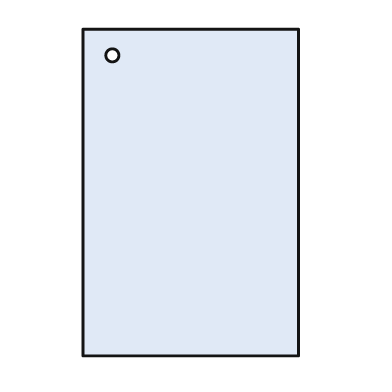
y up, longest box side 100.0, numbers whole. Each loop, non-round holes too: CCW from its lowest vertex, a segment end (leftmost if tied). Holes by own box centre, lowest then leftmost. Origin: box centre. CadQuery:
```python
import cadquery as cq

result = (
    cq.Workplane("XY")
    .moveTo(-33.0, -50.0)
    .lineTo(33.0, -50.0)
    .lineTo(33.0, 50.0)
    .lineTo(-33.0, 50.0)
    .close()
    .moveTo(-24.0, 42.0)
    .circle(2.0)
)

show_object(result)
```